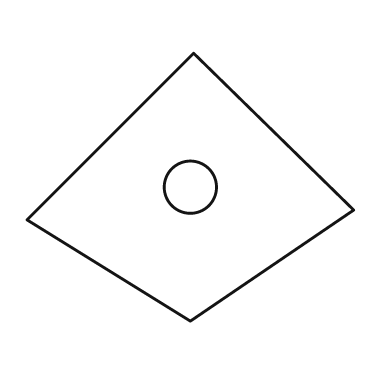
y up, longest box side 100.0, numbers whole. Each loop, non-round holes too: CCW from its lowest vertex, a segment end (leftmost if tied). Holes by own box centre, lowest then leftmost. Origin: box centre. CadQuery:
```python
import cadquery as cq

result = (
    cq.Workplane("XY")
    .moveTo(0.0, -41.0)
    .lineTo(50.0, -7.0)
    .lineTo(1.0, 41.0)
    .lineTo(-50.0, -10.0)
    .close()
    .moveTo(0.0, 0.0)
    .circle(8.0)
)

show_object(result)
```